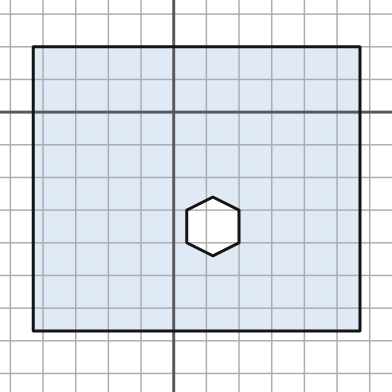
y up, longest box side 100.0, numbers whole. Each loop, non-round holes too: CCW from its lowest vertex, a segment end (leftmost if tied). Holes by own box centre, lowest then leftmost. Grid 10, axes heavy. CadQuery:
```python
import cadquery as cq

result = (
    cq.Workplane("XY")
    .moveTo(-43.0, -67.0)
    .lineTo(57.0, -67.0)
    .lineTo(57.0, 20.0)
    .lineTo(-43.0, 20.0)
    .close()
    .moveTo(12.0, -44.0)
    .lineTo(20.0, -40.0)
    .lineTo(20.0, -30.0)
    .lineTo(12.0, -26.0)
    .lineTo(4.0, -30.0)
    .lineTo(4.0, -40.0)
    .close()
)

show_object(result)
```